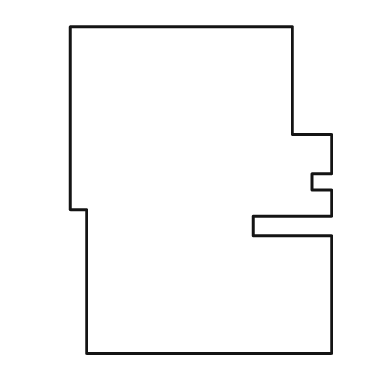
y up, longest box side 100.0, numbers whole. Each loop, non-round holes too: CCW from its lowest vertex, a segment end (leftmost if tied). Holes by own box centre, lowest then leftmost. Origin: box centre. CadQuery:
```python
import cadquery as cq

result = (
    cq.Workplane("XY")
    .moveTo(-35.0, -50.0)
    .lineTo(40.0, -50.0)
    .lineTo(40.0, -14.0)
    .lineTo(16.0, -14.0)
    .lineTo(16.0, -8.0)
    .lineTo(40.0, -8.0)
    .lineTo(40.0, 0.0)
    .lineTo(34.0, 0.0)
    .lineTo(34.0, 5.0)
    .lineTo(40.0, 5.0)
    .lineTo(40.0, 17.0)
    .lineTo(28.0, 17.0)
    .lineTo(28.0, 50.0)
    .lineTo(-40.0, 50.0)
    .lineTo(-40.0, -6.0)
    .lineTo(-35.0, -6.0)
    .close()
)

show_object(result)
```